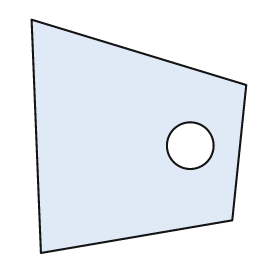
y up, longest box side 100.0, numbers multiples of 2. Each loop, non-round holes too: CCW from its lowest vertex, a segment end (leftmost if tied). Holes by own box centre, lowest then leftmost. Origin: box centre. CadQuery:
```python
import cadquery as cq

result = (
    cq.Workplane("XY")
    .moveTo(-42.0, -50.0)
    .lineTo(40.0, -36.0)
    .lineTo(46.0, 22.0)
    .lineTo(-46.0, 50.0)
    .close()
    .moveTo(22.0, -4.0)
    .circle(10.0)
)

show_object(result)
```